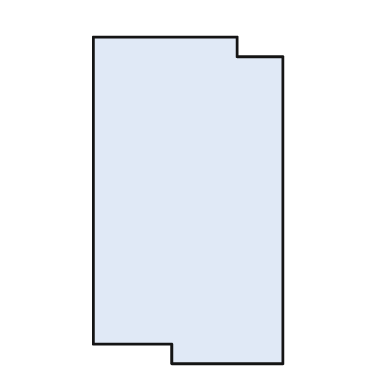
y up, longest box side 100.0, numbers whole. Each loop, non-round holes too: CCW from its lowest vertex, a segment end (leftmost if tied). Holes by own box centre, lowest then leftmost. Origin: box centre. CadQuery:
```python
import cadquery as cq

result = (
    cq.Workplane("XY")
    .moveTo(-5.0, -50.0)
    .lineTo(29.0, -50.0)
    .lineTo(29.0, 44.0)
    .lineTo(15.0, 44.0)
    .lineTo(15.0, 50.0)
    .lineTo(-29.0, 50.0)
    .lineTo(-29.0, -44.0)
    .lineTo(-5.0, -44.0)
    .close()
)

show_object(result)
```